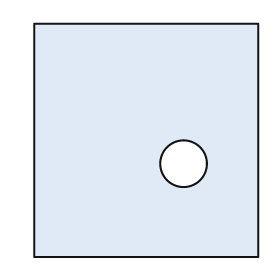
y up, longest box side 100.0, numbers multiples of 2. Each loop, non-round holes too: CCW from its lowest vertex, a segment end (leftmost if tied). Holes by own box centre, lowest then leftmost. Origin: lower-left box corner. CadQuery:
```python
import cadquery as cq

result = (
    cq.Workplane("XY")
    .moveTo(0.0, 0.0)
    .lineTo(96.0, 0.0)
    .lineTo(96.0, 100.0)
    .lineTo(0.0, 100.0)
    .close()
    .moveTo(64.0, 40.0)
    .circle(10.0)
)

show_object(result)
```